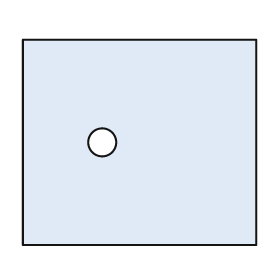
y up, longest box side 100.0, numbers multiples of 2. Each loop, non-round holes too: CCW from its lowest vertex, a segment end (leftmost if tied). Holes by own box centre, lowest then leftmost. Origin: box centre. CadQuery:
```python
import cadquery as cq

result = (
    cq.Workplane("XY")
    .moveTo(-50.0, -44.0)
    .lineTo(50.0, -44.0)
    .lineTo(50.0, 44.0)
    .lineTo(-50.0, 44.0)
    .close()
    .moveTo(-16.0, 0.0)
    .circle(6.0)
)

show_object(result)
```